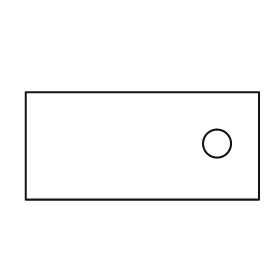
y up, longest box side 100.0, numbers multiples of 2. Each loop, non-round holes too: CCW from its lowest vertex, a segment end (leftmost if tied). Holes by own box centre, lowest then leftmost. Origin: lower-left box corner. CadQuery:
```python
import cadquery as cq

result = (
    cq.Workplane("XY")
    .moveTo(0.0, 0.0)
    .lineTo(100.0, 0.0)
    .lineTo(100.0, 46.0)
    .lineTo(0.0, 46.0)
    .close()
    .moveTo(82.0, 24.0)
    .circle(6.0)
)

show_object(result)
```